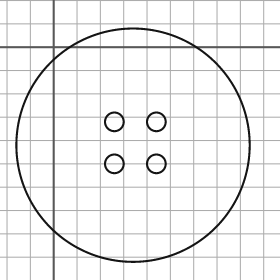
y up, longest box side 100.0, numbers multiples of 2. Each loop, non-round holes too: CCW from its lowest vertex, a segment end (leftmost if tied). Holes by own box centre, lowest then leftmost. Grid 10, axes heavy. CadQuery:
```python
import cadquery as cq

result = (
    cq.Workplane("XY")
    .moveTo(34.0, -42.0)
    .circle(50.0)
    .moveTo(26.0, -50.0)
    .circle(4.0)
    .moveTo(44.0, -50.0)
    .circle(4.0)
    .moveTo(26.0, -32.0)
    .circle(4.0)
    .moveTo(44.0, -32.0)
    .circle(4.0)
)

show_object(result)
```